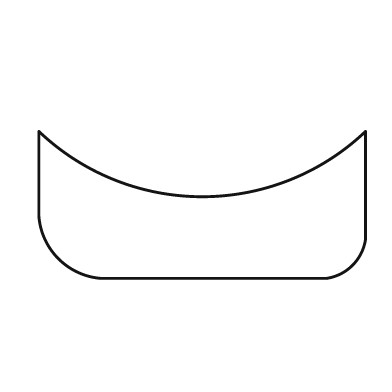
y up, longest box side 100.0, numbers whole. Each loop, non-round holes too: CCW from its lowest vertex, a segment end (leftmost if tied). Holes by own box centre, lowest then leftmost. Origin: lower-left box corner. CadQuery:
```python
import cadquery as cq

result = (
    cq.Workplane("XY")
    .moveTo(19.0, 0.0)
    .lineTo(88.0, 0.0)
    .threePointArc((96.0, 4.0), (100.0, 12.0))
    .lineTo(100.0, 45.0)
    .threePointArc((50.0, 25.0), (0.0, 45.0))
    .lineTo(0.0, 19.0)
    .threePointArc((6.0, 6.0), (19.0, 0.0))
    .close()
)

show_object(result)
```